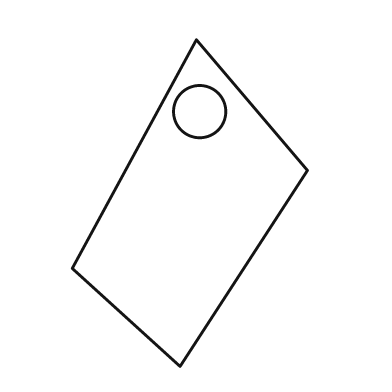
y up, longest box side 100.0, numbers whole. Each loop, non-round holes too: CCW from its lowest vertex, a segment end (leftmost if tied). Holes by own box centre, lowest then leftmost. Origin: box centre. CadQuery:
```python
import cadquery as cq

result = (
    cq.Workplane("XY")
    .moveTo(-3.0, -50.0)
    .lineTo(36.0, 10.0)
    .lineTo(2.0, 50.0)
    .lineTo(-36.0, -20.0)
    .close()
    .moveTo(3.0, 28.0)
    .circle(8.0)
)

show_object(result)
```